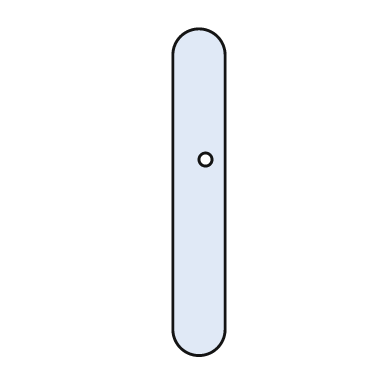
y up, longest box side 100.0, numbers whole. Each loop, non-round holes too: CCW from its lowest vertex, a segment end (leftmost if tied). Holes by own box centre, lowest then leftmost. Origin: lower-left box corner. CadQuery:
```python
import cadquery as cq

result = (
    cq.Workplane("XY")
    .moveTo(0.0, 8.0)
    .threePointArc((8.0, 0.0), (16.0, 8.0))
    .lineTo(16.0, 92.0)
    .threePointArc((8.0, 100.0), (0.0, 92.0))
    .close()
    .moveTo(10.0, 60.0)
    .circle(2.0)
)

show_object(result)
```